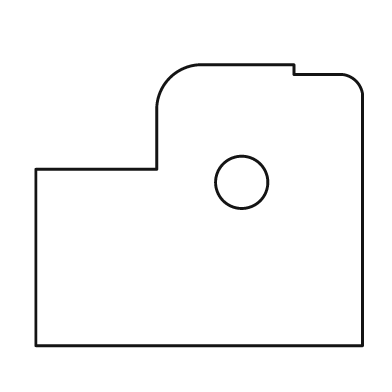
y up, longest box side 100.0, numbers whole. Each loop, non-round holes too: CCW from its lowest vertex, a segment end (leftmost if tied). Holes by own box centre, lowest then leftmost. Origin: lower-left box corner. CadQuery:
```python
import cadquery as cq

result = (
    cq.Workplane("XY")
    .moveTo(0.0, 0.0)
    .lineTo(100.0, 0.0)
    .lineTo(100.0, 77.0)
    .threePointArc((98.0, 81.0), (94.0, 83.0))
    .lineTo(79.0, 83.0)
    .lineTo(79.0, 86.0)
    .lineTo(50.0, 86.0)
    .threePointArc((41.0, 82.0), (37.0, 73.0))
    .lineTo(37.0, 54.0)
    .lineTo(0.0, 54.0)
    .close()
    .moveTo(63.0, 50.0)
    .circle(8.0)
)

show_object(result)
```